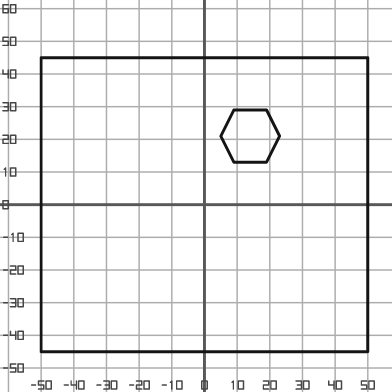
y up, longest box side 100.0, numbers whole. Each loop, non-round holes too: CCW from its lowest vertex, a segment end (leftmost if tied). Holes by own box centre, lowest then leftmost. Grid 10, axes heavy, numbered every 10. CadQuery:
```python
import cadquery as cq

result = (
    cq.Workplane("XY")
    .moveTo(-50.0, -45.0)
    .lineTo(50.0, -45.0)
    .lineTo(50.0, 45.0)
    .lineTo(-50.0, 45.0)
    .close()
    .moveTo(9.0, 13.0)
    .lineTo(19.0, 13.0)
    .lineTo(23.0, 21.0)
    .lineTo(19.0, 29.0)
    .lineTo(9.0, 29.0)
    .lineTo(5.0, 21.0)
    .close()
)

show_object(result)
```